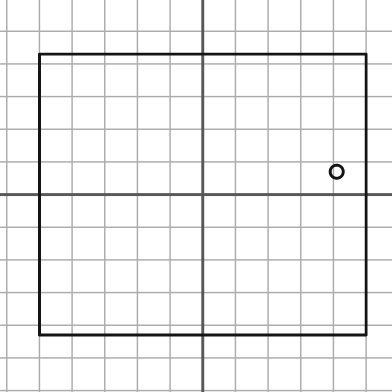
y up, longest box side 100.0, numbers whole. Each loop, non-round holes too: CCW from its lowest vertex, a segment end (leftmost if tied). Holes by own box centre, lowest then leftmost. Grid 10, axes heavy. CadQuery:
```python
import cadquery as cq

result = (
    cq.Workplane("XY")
    .moveTo(-50.0, -43.0)
    .lineTo(50.0, -43.0)
    .lineTo(50.0, 43.0)
    .lineTo(-50.0, 43.0)
    .close()
    .moveTo(41.0, 7.0)
    .circle(2.0)
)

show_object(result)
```